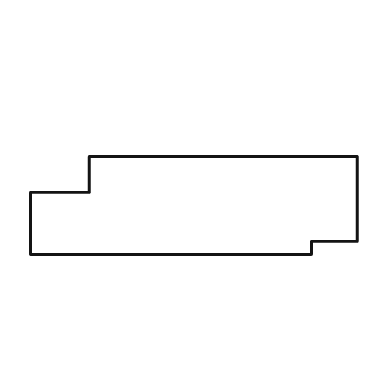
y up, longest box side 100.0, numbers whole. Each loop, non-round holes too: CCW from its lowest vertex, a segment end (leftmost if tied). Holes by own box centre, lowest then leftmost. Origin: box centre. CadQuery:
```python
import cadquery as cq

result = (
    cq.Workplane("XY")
    .moveTo(-50.0, -15.0)
    .lineTo(36.0, -15.0)
    .lineTo(36.0, -11.0)
    .lineTo(50.0, -11.0)
    .lineTo(50.0, 15.0)
    .lineTo(-32.0, 15.0)
    .lineTo(-32.0, 4.0)
    .lineTo(-50.0, 4.0)
    .close()
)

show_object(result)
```